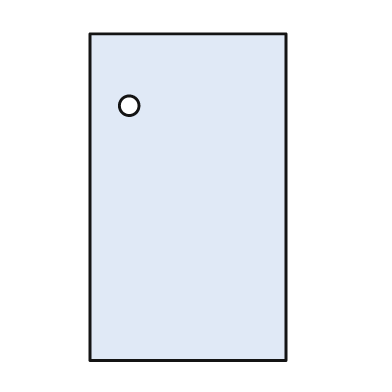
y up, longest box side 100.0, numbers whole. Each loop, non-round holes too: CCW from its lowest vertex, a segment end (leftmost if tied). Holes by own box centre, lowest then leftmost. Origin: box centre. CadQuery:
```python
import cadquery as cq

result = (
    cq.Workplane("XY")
    .moveTo(-30.0, -50.0)
    .lineTo(30.0, -50.0)
    .lineTo(30.0, 50.0)
    .lineTo(-30.0, 50.0)
    .close()
    .moveTo(-18.0, 28.0)
    .circle(3.0)
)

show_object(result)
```